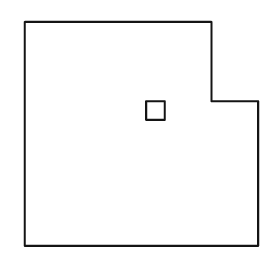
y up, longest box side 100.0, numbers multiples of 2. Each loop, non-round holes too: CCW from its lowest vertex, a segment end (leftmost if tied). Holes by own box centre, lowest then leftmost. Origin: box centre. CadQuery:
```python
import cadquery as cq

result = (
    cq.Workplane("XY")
    .moveTo(-50.0, -48.0)
    .lineTo(50.0, -48.0)
    .lineTo(50.0, 14.0)
    .lineTo(30.0, 14.0)
    .lineTo(30.0, 48.0)
    .lineTo(-50.0, 48.0)
    .close()
    .moveTo(2.0, 6.0)
    .lineTo(10.0, 6.0)
    .lineTo(10.0, 14.0)
    .lineTo(2.0, 14.0)
    .close()
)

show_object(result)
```